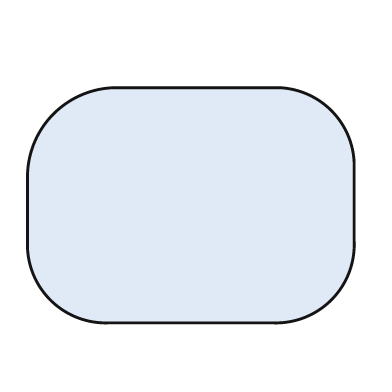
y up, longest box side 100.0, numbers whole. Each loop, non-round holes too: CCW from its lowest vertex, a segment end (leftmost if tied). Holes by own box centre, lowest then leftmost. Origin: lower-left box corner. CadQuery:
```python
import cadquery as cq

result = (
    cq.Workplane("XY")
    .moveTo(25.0, 0.0)
    .lineTo(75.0, 0.0)
    .threePointArc((93.0, 7.0), (100.0, 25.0))
    .lineTo(100.0, 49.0)
    .threePointArc((93.0, 65.0), (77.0, 72.0))
    .lineTo(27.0, 72.0)
    .threePointArc((8.0, 64.0), (0.0, 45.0))
    .lineTo(0.0, 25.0)
    .threePointArc((7.0, 7.0), (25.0, 0.0))
    .close()
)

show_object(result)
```